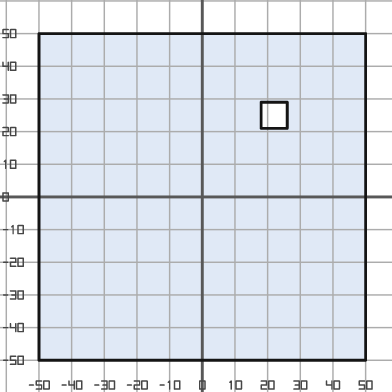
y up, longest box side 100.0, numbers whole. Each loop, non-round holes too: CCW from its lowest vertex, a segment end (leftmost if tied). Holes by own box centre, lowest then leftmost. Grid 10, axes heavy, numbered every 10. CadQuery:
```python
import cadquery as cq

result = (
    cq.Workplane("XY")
    .moveTo(-50.0, -50.0)
    .lineTo(50.0, -50.0)
    .lineTo(50.0, 50.0)
    .lineTo(-50.0, 50.0)
    .close()
    .moveTo(18.0, 21.0)
    .lineTo(26.0, 21.0)
    .lineTo(26.0, 29.0)
    .lineTo(18.0, 29.0)
    .close()
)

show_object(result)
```